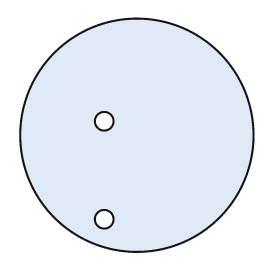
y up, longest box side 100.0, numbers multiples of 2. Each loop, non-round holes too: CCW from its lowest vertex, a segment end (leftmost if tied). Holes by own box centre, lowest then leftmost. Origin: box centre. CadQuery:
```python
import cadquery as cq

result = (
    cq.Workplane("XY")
    .moveTo(0.0, 0.0)
    .circle(50.0)
    .moveTo(-14.0, -36.0)
    .circle(4.0)
    .moveTo(-14.0, 6.0)
    .circle(4.0)
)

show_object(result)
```